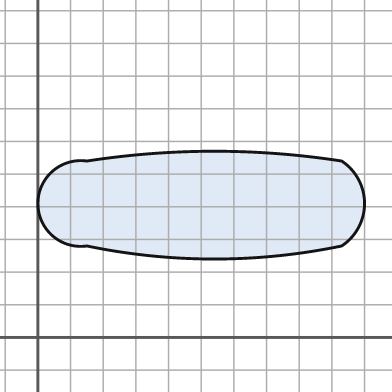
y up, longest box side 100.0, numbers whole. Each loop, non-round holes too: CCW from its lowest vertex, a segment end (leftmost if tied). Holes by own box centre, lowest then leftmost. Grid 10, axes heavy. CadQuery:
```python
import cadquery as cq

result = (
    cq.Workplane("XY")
    .moveTo(15.0, 28.0)
    .threePointArc((54.0, 24.0), (93.0, 28.0))
    .threePointArc((100.0, 41.0), (93.0, 54.0))
    .threePointArc((54.0, 57.0), (15.0, 54.0))
    .threePointArc((0.0, 41.0), (15.0, 28.0))
    .close()
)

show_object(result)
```